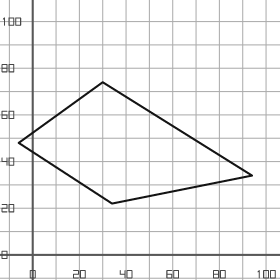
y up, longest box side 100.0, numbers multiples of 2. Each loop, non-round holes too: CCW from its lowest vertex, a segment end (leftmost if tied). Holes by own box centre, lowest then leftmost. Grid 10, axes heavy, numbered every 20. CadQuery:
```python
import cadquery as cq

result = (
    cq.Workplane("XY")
    .moveTo(34.0, 22.0)
    .lineTo(94.0, 34.0)
    .lineTo(30.0, 74.0)
    .lineTo(-6.0, 48.0)
    .close()
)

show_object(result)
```